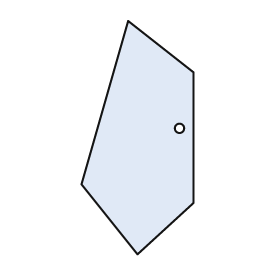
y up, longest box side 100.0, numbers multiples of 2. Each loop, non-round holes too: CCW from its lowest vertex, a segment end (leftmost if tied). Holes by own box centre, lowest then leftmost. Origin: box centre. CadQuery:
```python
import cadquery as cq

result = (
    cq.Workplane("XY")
    .moveTo(0.0, -50.0)
    .lineTo(24.0, -28.0)
    .lineTo(24.0, 28.0)
    .lineTo(-4.0, 50.0)
    .lineTo(-24.0, -20.0)
    .close()
    .moveTo(18.0, 4.0)
    .circle(2.0)
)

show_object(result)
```